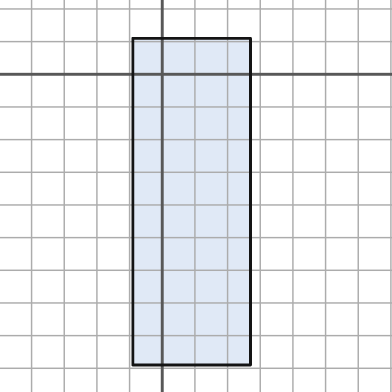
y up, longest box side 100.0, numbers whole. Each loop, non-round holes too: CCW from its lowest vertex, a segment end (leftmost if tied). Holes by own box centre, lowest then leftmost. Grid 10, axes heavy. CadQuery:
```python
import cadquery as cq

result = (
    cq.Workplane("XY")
    .moveTo(-9.0, -89.0)
    .lineTo(27.0, -89.0)
    .lineTo(27.0, 11.0)
    .lineTo(-9.0, 11.0)
    .close()
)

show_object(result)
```